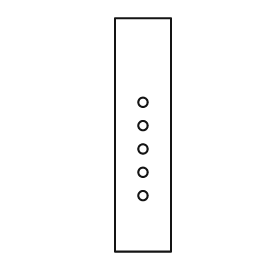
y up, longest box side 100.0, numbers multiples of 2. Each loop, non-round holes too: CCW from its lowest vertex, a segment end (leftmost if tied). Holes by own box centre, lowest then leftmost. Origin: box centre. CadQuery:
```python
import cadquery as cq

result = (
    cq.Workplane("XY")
    .moveTo(-12.0, -50.0)
    .lineTo(12.0, -50.0)
    .lineTo(12.0, 50.0)
    .lineTo(-12.0, 50.0)
    .close()
    .moveTo(0.0, -26.0)
    .circle(2.0)
    .moveTo(0.0, -16.0)
    .circle(2.0)
    .moveTo(0.0, -6.0)
    .circle(2.0)
    .moveTo(0.0, 4.0)
    .circle(2.0)
    .moveTo(0.0, 14.0)
    .circle(2.0)
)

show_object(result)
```